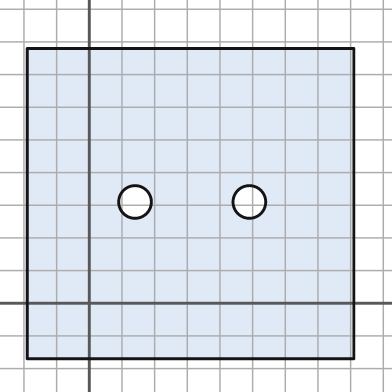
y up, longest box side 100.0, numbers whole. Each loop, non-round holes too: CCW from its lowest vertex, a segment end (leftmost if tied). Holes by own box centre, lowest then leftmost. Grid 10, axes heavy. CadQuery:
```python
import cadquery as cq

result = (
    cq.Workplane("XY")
    .moveTo(-19.0, -17.0)
    .lineTo(81.0, -17.0)
    .lineTo(81.0, 78.0)
    .lineTo(-19.0, 78.0)
    .close()
    .moveTo(14.0, 31.0)
    .circle(5.0)
    .moveTo(49.0, 31.0)
    .circle(5.0)
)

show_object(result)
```